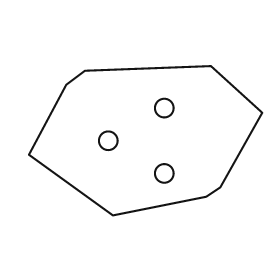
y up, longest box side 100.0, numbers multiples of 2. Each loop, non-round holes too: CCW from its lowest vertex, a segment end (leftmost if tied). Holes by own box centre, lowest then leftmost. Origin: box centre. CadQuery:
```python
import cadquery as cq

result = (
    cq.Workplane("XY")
    .moveTo(-14.0, -32.0)
    .lineTo(26.0, -24.0)
    .lineTo(32.0, -20.0)
    .lineTo(50.0, 12.0)
    .lineTo(28.0, 32.0)
    .lineTo(-26.0, 30.0)
    .lineTo(-34.0, 24.0)
    .lineTo(-50.0, -6.0)
    .close()
    .moveTo(8.0, -14.0)
    .circle(4.0)
    .moveTo(-16.0, 0.0)
    .circle(4.0)
    .moveTo(8.0, 14.0)
    .circle(4.0)
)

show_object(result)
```